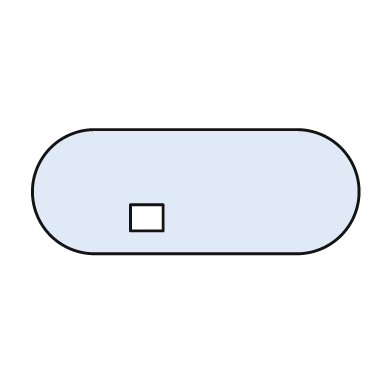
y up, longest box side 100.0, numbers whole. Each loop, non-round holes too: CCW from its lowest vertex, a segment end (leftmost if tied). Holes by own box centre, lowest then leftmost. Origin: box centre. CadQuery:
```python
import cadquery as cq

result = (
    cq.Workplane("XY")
    .moveTo(-31.0, -19.0)
    .lineTo(31.0, -19.0)
    .threePointArc((50.0, 0.0), (31.0, 19.0))
    .lineTo(-31.0, 19.0)
    .threePointArc((-50.0, 0.0), (-31.0, -19.0))
    .close()
    .moveTo(-20.0, -12.0)
    .lineTo(-10.0, -12.0)
    .lineTo(-10.0, -4.0)
    .lineTo(-20.0, -4.0)
    .close()
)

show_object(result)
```